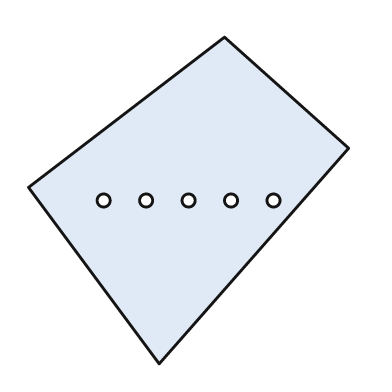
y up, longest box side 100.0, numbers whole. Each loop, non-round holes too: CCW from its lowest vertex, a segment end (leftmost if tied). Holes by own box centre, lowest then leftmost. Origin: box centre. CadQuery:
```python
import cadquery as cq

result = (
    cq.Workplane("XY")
    .moveTo(-9.0, -50.0)
    .lineTo(49.0, 16.0)
    .lineTo(11.0, 50.0)
    .lineTo(-49.0, 4.0)
    .close()
    .moveTo(-26.0, 0.0)
    .circle(2.0)
    .moveTo(-13.0, 0.0)
    .circle(2.0)
    .moveTo(0.0, 0.0)
    .circle(2.0)
    .moveTo(13.0, 0.0)
    .circle(2.0)
    .moveTo(26.0, 0.0)
    .circle(2.0)
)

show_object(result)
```